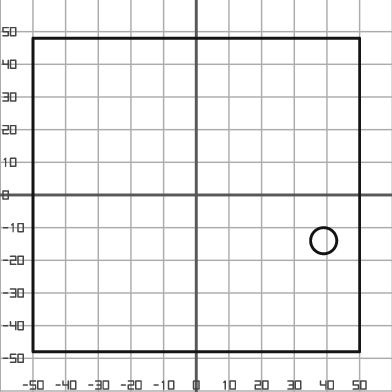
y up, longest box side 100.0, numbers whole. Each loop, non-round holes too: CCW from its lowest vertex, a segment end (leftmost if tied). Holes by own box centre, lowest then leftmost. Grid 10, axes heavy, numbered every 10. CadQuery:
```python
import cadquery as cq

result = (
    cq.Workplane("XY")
    .moveTo(-50.0, -48.0)
    .lineTo(50.0, -48.0)
    .lineTo(50.0, 48.0)
    .lineTo(-50.0, 48.0)
    .close()
    .moveTo(39.0, -14.0)
    .circle(4.0)
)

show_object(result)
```